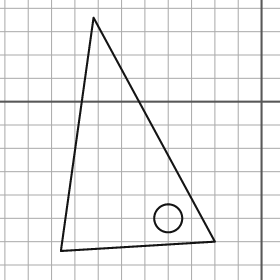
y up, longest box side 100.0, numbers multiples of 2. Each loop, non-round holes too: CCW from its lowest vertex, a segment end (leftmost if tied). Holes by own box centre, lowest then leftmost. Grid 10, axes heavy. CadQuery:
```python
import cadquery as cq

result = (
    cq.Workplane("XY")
    .moveTo(-86.0, -64.0)
    .lineTo(-20.0, -60.0)
    .lineTo(-72.0, 36.0)
    .close()
    .moveTo(-40.0, -50.0)
    .circle(6.0)
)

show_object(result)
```